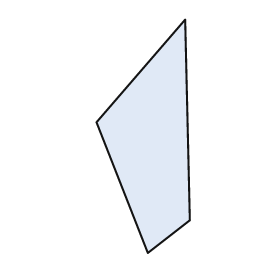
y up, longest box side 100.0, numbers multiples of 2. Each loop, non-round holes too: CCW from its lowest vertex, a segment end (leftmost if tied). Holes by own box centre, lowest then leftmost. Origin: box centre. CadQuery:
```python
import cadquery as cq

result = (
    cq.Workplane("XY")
    .moveTo(2.0, -50.0)
    .lineTo(20.0, -36.0)
    .lineTo(18.0, 50.0)
    .lineTo(-20.0, 6.0)
    .close()
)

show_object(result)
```